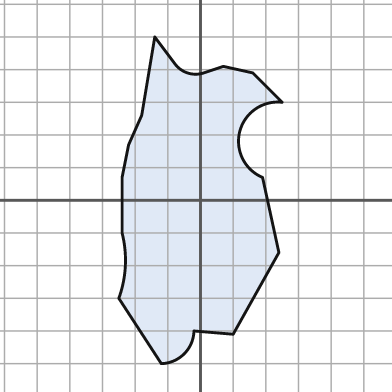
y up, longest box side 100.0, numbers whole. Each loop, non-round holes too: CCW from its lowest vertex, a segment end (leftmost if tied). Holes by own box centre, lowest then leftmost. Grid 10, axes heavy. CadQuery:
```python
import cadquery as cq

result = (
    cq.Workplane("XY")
    .moveTo(-12.0, -50.0)
    .threePointArc((-5.0, -47.0), (-2.0, -40.0))
    .lineTo(10.0, -41.0)
    .lineTo(24.0, -16.0)
    .lineTo(19.0, 7.0)
    .threePointArc((12.0, 21.0), (25.0, 30.0))
    .lineTo(16.0, 39.0)
    .lineTo(7.0, 41.0)
    .lineTo(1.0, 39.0)
    .threePointArc((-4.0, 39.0), (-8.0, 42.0))
    .lineTo(-14.0, 50.0)
    .lineTo(-18.0, 26.0)
    .lineTo(-22.0, 17.0)
    .lineTo(-24.0, 7.0)
    .lineTo(-24.0, -10.0)
    .threePointArc((-23.0, -20.0), (-25.0, -30.0))
    .close()
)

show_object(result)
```